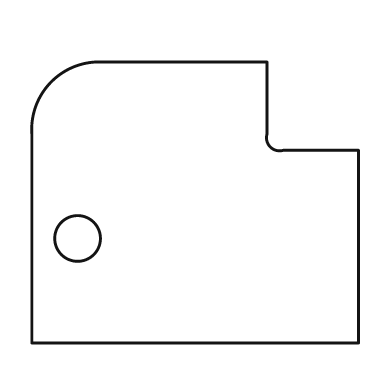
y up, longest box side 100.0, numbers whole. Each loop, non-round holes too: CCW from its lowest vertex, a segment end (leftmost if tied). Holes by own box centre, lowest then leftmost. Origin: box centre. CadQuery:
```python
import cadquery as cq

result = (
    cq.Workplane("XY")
    .moveTo(-50.0, -43.0)
    .lineTo(50.0, -43.0)
    .lineTo(50.0, 16.0)
    .lineTo(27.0, 16.0)
    .threePointArc((23.0, 17.0), (22.0, 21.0))
    .lineTo(22.0, 43.0)
    .lineTo(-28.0, 43.0)
    .threePointArc((-44.0, 37.0), (-50.0, 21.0))
    .close()
    .moveTo(-36.0, -11.0)
    .circle(7.0)
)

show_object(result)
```